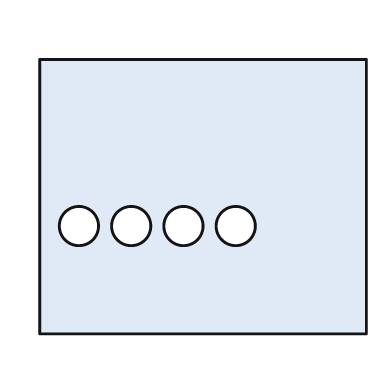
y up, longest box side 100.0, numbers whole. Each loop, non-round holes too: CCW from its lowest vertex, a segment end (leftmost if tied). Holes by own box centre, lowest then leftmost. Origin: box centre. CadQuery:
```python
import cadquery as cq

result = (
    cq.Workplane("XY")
    .moveTo(-50.0, -42.0)
    .lineTo(50.0, -42.0)
    .lineTo(50.0, 42.0)
    .lineTo(-50.0, 42.0)
    .close()
    .moveTo(-38.0, -9.0)
    .circle(6.0)
    .moveTo(-22.0, -9.0)
    .circle(6.0)
    .moveTo(-6.0, -9.0)
    .circle(6.0)
    .moveTo(10.0, -9.0)
    .circle(6.0)
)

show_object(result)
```